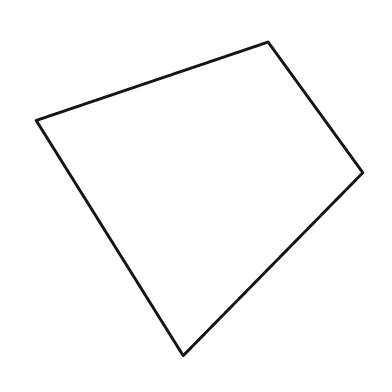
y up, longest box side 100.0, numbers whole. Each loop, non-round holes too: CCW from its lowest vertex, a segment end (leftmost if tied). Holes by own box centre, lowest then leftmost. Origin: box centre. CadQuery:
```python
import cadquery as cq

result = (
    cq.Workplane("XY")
    .moveTo(-5.0, -48.0)
    .lineTo(50.0, 8.0)
    .lineTo(21.0, 48.0)
    .lineTo(-50.0, 24.0)
    .close()
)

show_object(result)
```